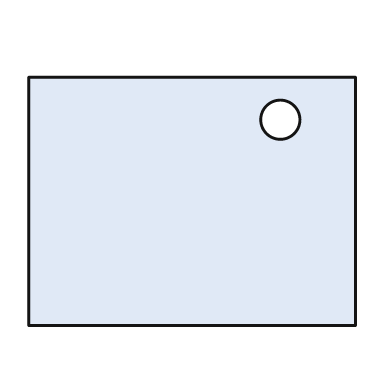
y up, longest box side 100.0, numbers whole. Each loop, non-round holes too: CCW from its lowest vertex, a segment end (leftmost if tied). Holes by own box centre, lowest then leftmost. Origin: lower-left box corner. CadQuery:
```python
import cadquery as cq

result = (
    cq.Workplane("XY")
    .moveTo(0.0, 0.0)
    .lineTo(100.0, 0.0)
    .lineTo(100.0, 76.0)
    .lineTo(0.0, 76.0)
    .close()
    .moveTo(77.0, 63.0)
    .circle(6.0)
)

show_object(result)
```